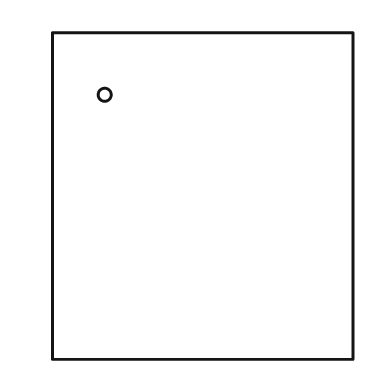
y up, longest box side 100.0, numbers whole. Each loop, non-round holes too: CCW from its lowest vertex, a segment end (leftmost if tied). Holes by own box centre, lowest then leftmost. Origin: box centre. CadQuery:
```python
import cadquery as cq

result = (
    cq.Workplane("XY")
    .moveTo(-46.0, -50.0)
    .lineTo(46.0, -50.0)
    .lineTo(46.0, 50.0)
    .lineTo(-46.0, 50.0)
    .close()
    .moveTo(-30.0, 31.0)
    .circle(2.0)
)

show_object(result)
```